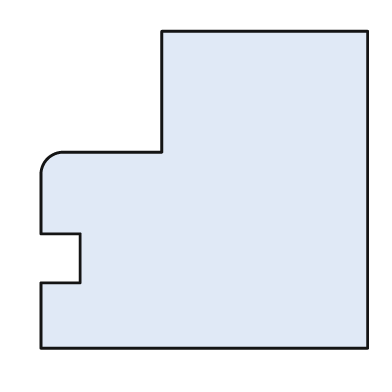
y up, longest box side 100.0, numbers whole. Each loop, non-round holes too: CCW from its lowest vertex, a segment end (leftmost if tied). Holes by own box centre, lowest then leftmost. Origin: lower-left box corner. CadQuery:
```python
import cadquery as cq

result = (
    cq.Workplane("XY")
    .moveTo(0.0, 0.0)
    .lineTo(100.0, 0.0)
    .lineTo(100.0, 97.0)
    .lineTo(37.0, 97.0)
    .lineTo(37.0, 60.0)
    .lineTo(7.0, 60.0)
    .threePointArc((2.0, 58.0), (0.0, 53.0))
    .lineTo(0.0, 35.0)
    .lineTo(12.0, 35.0)
    .lineTo(12.0, 20.0)
    .lineTo(0.0, 20.0)
    .close()
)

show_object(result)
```